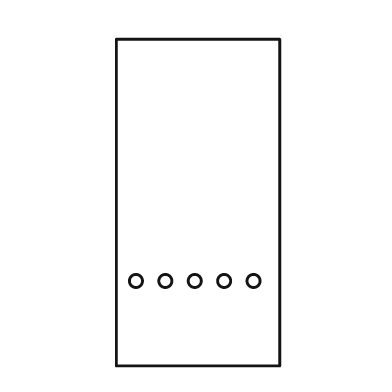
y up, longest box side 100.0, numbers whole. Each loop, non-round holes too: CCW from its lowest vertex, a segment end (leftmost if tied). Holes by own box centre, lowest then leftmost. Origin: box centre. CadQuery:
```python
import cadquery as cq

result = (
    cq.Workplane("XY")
    .moveTo(-25.0, -50.0)
    .lineTo(25.0, -50.0)
    .lineTo(25.0, 50.0)
    .lineTo(-25.0, 50.0)
    .close()
    .moveTo(-19.0, -24.0)
    .circle(2.0)
    .moveTo(-10.0, -24.0)
    .circle(2.0)
    .moveTo(-1.0, -24.0)
    .circle(2.0)
    .moveTo(8.0, -24.0)
    .circle(2.0)
    .moveTo(17.0, -24.0)
    .circle(2.0)
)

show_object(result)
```